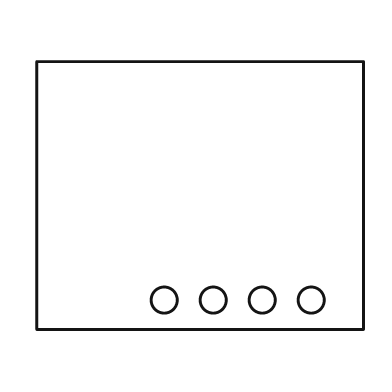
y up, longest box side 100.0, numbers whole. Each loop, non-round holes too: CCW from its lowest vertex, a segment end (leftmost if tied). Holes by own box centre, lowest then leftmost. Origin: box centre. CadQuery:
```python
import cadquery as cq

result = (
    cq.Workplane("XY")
    .moveTo(-50.0, -41.0)
    .lineTo(50.0, -41.0)
    .lineTo(50.0, 41.0)
    .lineTo(-50.0, 41.0)
    .close()
    .moveTo(-11.0, -32.0)
    .circle(4.0)
    .moveTo(4.0, -32.0)
    .circle(4.0)
    .moveTo(19.0, -32.0)
    .circle(4.0)
    .moveTo(34.0, -32.0)
    .circle(4.0)
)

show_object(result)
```